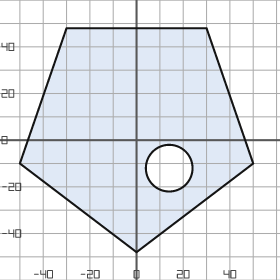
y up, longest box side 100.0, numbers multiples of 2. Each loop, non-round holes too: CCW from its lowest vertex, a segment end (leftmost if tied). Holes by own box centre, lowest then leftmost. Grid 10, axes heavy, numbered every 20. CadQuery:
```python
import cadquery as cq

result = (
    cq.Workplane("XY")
    .moveTo(0.0, -48.0)
    .lineTo(50.0, -10.0)
    .lineTo(30.0, 48.0)
    .lineTo(-30.0, 48.0)
    .lineTo(-50.0, -10.0)
    .close()
    .moveTo(14.0, -12.0)
    .circle(10.0)
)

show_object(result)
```